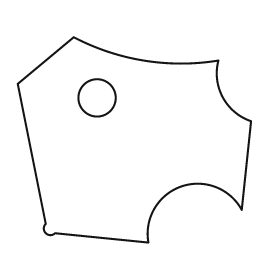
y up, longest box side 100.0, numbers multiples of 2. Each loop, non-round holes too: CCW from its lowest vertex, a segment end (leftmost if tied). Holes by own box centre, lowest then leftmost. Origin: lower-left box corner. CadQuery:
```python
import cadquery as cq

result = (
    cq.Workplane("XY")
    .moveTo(56.0, 0.0)
    .threePointArc((70.0, 24.0), (96.0, 14.0))
    .lineTo(100.0, 52.0)
    .threePointArc((88.0, 62.0), (86.0, 78.0))
    .threePointArc((54.0, 78.0), (24.0, 88.0))
    .lineTo(0.0, 68.0)
    .lineTo(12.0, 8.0)
    .threePointArc((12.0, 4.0), (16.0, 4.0))
    .close()
    .moveTo(34.0, 62.0)
    .circle(8.0)
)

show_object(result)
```